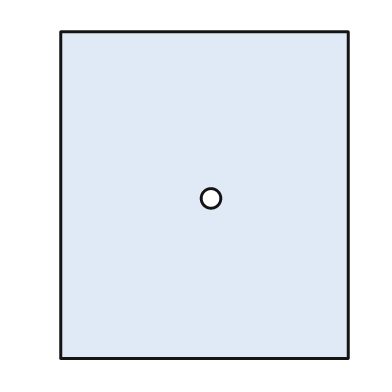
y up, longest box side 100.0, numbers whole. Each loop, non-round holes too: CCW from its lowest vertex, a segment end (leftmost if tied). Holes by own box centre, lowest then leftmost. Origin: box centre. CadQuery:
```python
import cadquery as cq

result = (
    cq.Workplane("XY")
    .moveTo(-44.0, -50.0)
    .lineTo(44.0, -50.0)
    .lineTo(44.0, 50.0)
    .lineTo(-44.0, 50.0)
    .close()
    .moveTo(2.0, -1.0)
    .circle(3.0)
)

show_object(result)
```